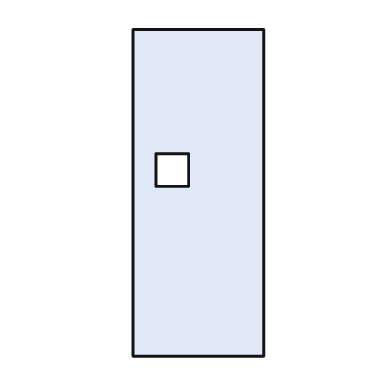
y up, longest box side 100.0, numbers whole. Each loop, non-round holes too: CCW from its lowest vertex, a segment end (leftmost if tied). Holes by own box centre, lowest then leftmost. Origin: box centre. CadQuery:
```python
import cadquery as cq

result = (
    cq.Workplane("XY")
    .moveTo(-20.0, -50.0)
    .lineTo(20.0, -50.0)
    .lineTo(20.0, 50.0)
    .lineTo(-20.0, 50.0)
    .close()
    .moveTo(-13.0, 2.0)
    .lineTo(-3.0, 2.0)
    .lineTo(-3.0, 12.0)
    .lineTo(-13.0, 12.0)
    .close()
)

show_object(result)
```